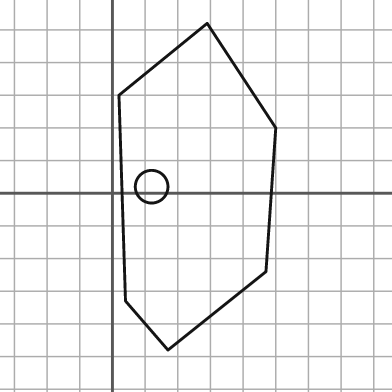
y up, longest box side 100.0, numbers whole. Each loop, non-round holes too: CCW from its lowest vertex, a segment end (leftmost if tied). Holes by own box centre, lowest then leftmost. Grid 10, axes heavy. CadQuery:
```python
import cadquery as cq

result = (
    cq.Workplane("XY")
    .moveTo(17.0, -48.0)
    .lineTo(47.0, -24.0)
    .lineTo(50.0, 20.0)
    .lineTo(29.0, 52.0)
    .lineTo(2.0, 30.0)
    .lineTo(4.0, -33.0)
    .close()
    .moveTo(12.0, 2.0)
    .circle(5.0)
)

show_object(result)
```